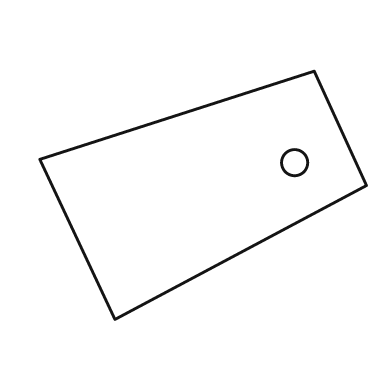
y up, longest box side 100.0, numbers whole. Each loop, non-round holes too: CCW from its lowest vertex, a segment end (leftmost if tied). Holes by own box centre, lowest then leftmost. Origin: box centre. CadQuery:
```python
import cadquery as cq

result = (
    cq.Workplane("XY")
    .moveTo(-27.0, -38.0)
    .lineTo(50.0, 3.0)
    .lineTo(34.0, 38.0)
    .lineTo(-50.0, 11.0)
    .close()
    .moveTo(28.0, 10.0)
    .circle(4.0)
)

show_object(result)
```